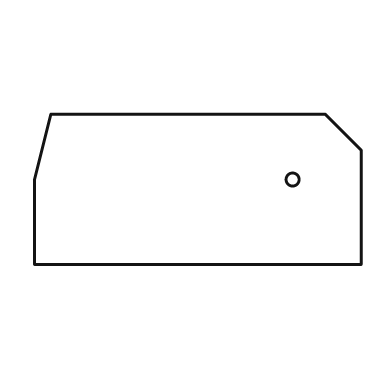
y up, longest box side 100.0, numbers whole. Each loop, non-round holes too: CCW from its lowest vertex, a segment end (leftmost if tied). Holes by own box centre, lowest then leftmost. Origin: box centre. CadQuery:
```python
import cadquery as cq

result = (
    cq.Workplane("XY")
    .moveTo(-50.0, -23.0)
    .lineTo(50.0, -23.0)
    .lineTo(50.0, 12.0)
    .lineTo(39.0, 23.0)
    .lineTo(-45.0, 23.0)
    .lineTo(-50.0, 3.0)
    .close()
    .moveTo(29.0, 3.0)
    .circle(2.0)
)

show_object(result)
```